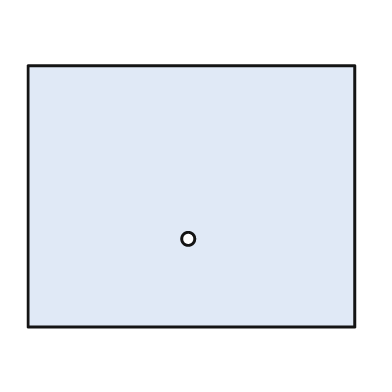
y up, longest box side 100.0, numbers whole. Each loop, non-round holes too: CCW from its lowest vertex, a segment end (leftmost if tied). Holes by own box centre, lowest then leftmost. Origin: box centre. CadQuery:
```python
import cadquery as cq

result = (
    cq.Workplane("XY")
    .moveTo(-50.0, -40.0)
    .lineTo(50.0, -40.0)
    .lineTo(50.0, 40.0)
    .lineTo(-50.0, 40.0)
    .close()
    .moveTo(-1.0, -13.0)
    .circle(2.0)
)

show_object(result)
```